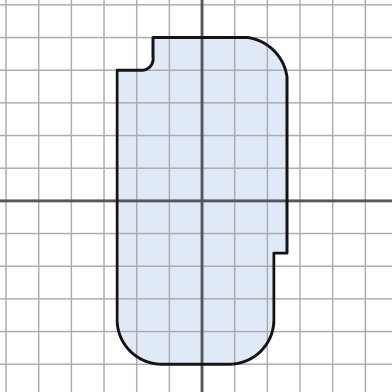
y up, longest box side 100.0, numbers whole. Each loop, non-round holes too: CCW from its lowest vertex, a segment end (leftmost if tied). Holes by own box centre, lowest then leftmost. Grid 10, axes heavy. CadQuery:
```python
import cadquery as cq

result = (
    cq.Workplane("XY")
    .moveTo(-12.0, -50.0)
    .lineTo(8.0, -50.0)
    .threePointArc((18.0, -46.0), (22.0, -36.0))
    .lineTo(22.0, -16.0)
    .lineTo(26.0, -16.0)
    .lineTo(26.0, 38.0)
    .threePointArc((22.0, 46.0), (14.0, 50.0))
    .lineTo(-15.0, 50.0)
    .lineTo(-15.0, 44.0)
    .threePointArc((-16.0, 41.0), (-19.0, 40.0))
    .lineTo(-26.0, 40.0)
    .lineTo(-26.0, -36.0)
    .threePointArc((-22.0, -46.0), (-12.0, -50.0))
    .close()
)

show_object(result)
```